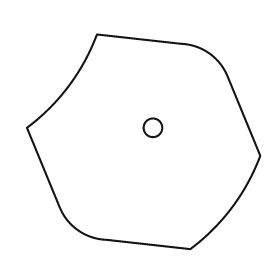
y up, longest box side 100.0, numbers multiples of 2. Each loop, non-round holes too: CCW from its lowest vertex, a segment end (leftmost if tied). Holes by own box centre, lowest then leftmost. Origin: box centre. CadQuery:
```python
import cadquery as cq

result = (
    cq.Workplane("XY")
    .moveTo(20.0, -46.0)
    .threePointArc((38.0, -28.0), (50.0, -6.0))
    .lineTo(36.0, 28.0)
    .threePointArc((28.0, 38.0), (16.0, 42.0))
    .lineTo(-20.0, 46.0)
    .threePointArc((-32.0, 24.0), (-50.0, 6.0))
    .lineTo(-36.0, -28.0)
    .threePointArc((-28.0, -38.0), (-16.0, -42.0))
    .close()
    .moveTo(4.0, 6.0)
    .circle(4.0)
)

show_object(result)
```